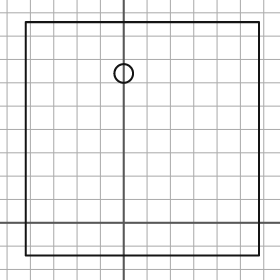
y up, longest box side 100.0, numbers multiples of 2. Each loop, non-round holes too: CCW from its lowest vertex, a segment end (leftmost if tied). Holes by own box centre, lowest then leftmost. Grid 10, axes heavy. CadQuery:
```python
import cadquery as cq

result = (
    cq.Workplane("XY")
    .moveTo(-42.0, -14.0)
    .lineTo(58.0, -14.0)
    .lineTo(58.0, 86.0)
    .lineTo(-42.0, 86.0)
    .close()
    .moveTo(0.0, 64.0)
    .circle(4.0)
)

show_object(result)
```